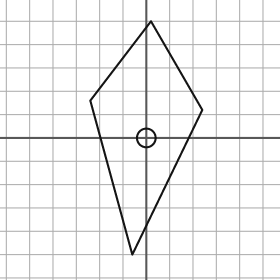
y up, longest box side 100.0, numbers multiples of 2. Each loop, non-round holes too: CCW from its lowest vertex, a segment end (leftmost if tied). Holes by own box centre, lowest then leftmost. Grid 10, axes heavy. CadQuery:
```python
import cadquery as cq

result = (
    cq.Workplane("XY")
    .moveTo(-6.0, -50.0)
    .lineTo(24.0, 12.0)
    .lineTo(2.0, 50.0)
    .lineTo(-24.0, 16.0)
    .close()
    .moveTo(0.0, 0.0)
    .circle(4.0)
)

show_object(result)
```